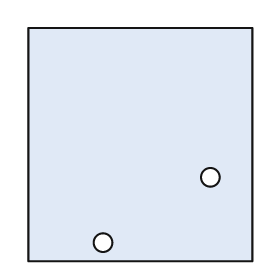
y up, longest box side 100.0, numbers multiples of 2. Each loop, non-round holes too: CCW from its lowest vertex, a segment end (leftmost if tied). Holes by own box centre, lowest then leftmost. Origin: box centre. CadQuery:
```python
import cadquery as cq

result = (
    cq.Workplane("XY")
    .moveTo(-48.0, -50.0)
    .lineTo(48.0, -50.0)
    .lineTo(48.0, 50.0)
    .lineTo(-48.0, 50.0)
    .close()
    .moveTo(-16.0, -42.0)
    .circle(4.0)
    .moveTo(30.0, -14.0)
    .circle(4.0)
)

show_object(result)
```